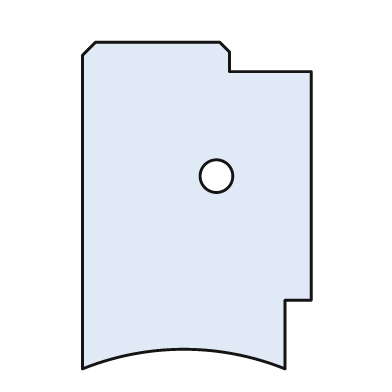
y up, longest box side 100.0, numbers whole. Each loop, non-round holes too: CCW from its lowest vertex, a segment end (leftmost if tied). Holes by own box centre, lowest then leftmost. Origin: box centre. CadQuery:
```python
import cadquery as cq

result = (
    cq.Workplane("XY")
    .moveTo(-35.0, -50.0)
    .threePointArc((-4.0, -44.0), (27.0, -50.0))
    .lineTo(27.0, -29.0)
    .lineTo(35.0, -29.0)
    .lineTo(35.0, 41.0)
    .lineTo(10.0, 41.0)
    .lineTo(10.0, 47.0)
    .lineTo(7.0, 50.0)
    .lineTo(-31.0, 50.0)
    .lineTo(-35.0, 46.0)
    .close()
    .moveTo(6.0, 9.0)
    .circle(5.0)
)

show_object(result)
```